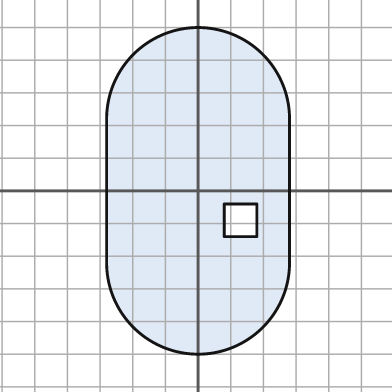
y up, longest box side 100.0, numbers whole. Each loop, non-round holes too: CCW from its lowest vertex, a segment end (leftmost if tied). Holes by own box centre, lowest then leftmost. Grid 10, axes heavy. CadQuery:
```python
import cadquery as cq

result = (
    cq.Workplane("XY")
    .moveTo(-28.0, -22.0)
    .threePointArc((0.0, -50.0), (28.0, -22.0))
    .lineTo(28.0, 22.0)
    .threePointArc((0.0, 50.0), (-28.0, 22.0))
    .close()
    .moveTo(8.0, -14.0)
    .lineTo(18.0, -14.0)
    .lineTo(18.0, -4.0)
    .lineTo(8.0, -4.0)
    .close()
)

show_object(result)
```